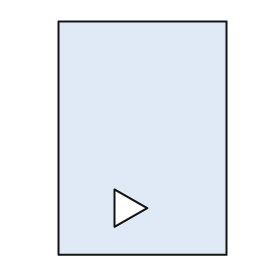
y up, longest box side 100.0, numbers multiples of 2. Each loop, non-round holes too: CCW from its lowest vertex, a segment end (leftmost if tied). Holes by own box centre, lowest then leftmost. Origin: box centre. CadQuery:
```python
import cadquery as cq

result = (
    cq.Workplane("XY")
    .moveTo(-36.0, -50.0)
    .lineTo(36.0, -50.0)
    .lineTo(36.0, 50.0)
    .lineTo(-36.0, 50.0)
    .close()
    .moveTo(-12.0, -38.0)
    .lineTo(2.0, -30.0)
    .lineTo(-12.0, -22.0)
    .close()
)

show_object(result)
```